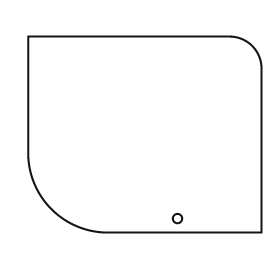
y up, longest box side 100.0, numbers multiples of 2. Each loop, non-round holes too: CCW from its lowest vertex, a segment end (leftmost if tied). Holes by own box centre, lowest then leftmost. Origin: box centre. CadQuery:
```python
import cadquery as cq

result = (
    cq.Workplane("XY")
    .moveTo(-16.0, -42.0)
    .lineTo(50.0, -42.0)
    .lineTo(50.0, 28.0)
    .threePointArc((46.0, 38.0), (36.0, 42.0))
    .lineTo(-50.0, 42.0)
    .lineTo(-50.0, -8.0)
    .threePointArc((-40.0, -32.0), (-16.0, -42.0))
    .close()
    .moveTo(14.0, -36.0)
    .circle(2.0)
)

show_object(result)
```